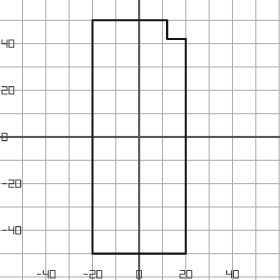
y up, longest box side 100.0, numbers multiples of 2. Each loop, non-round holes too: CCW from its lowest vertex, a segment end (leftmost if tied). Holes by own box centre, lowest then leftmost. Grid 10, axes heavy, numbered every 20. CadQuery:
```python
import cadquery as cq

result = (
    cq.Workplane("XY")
    .moveTo(-20.0, -50.0)
    .lineTo(20.0, -50.0)
    .lineTo(20.0, 42.0)
    .lineTo(12.0, 42.0)
    .lineTo(12.0, 50.0)
    .lineTo(-20.0, 50.0)
    .close()
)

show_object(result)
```